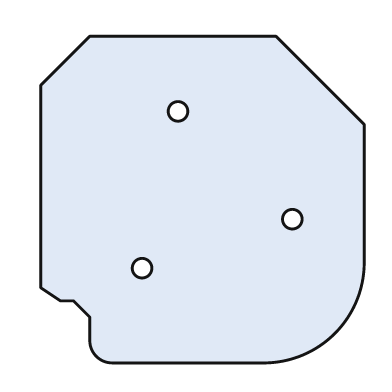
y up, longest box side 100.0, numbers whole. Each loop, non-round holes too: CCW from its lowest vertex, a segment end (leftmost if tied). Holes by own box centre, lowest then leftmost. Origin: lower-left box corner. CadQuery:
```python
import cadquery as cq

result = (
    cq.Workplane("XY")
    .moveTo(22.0, 0.0)
    .lineTo(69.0, 0.0)
    .threePointArc((90.0, 9.0), (99.0, 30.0))
    .lineTo(99.0, 73.0)
    .lineTo(72.0, 100.0)
    .lineTo(15.0, 100.0)
    .lineTo(0.0, 85.0)
    .lineTo(0.0, 23.0)
    .lineTo(6.0, 19.0)
    .lineTo(10.0, 19.0)
    .lineTo(15.0, 14.0)
    .lineTo(15.0, 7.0)
    .threePointArc((17.0, 2.0), (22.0, 0.0))
    .close()
    .moveTo(31.0, 29.0)
    .circle(3.0)
    .moveTo(77.0, 44.0)
    .circle(3.0)
    .moveTo(42.0, 77.0)
    .circle(3.0)
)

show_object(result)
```